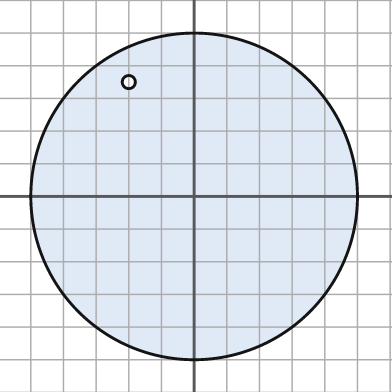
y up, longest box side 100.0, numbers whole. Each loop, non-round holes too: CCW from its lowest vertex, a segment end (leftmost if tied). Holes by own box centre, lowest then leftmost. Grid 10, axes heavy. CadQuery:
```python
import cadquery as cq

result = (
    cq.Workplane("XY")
    .moveTo(0.0, 0.0)
    .circle(50.0)
    .moveTo(-20.0, 35.0)
    .circle(2.0)
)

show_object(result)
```